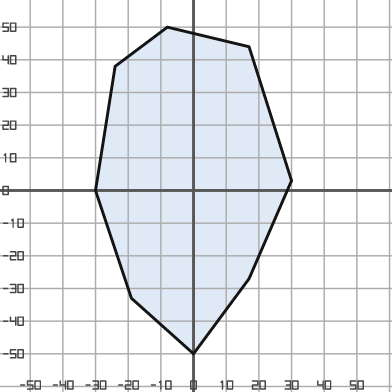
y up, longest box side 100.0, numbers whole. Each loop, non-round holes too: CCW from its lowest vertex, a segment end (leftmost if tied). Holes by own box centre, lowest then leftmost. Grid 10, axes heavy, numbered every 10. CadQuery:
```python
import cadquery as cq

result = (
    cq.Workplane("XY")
    .moveTo(0.0, -50.0)
    .lineTo(17.0, -27.0)
    .lineTo(30.0, 3.0)
    .lineTo(17.0, 44.0)
    .lineTo(-8.0, 50.0)
    .lineTo(-24.0, 38.0)
    .lineTo(-30.0, 0.0)
    .lineTo(-19.0, -33.0)
    .close()
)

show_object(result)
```